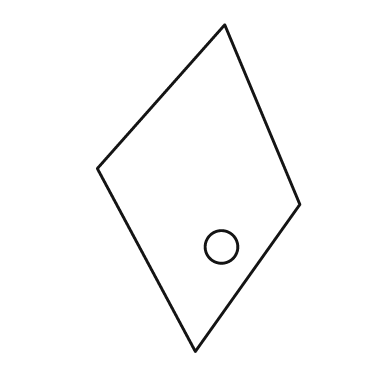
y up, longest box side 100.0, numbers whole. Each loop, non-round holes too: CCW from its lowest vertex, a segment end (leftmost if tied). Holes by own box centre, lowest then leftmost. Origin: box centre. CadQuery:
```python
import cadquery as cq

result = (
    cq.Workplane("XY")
    .moveTo(-1.0, -50.0)
    .lineTo(31.0, -5.0)
    .lineTo(8.0, 50.0)
    .lineTo(-31.0, 6.0)
    .close()
    .moveTo(7.0, -18.0)
    .circle(5.0)
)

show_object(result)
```